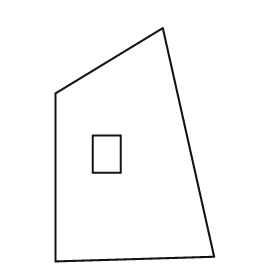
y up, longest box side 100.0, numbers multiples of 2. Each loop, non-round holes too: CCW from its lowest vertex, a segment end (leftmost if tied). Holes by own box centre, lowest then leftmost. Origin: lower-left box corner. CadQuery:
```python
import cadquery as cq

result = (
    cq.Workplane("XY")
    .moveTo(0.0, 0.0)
    .lineTo(68.0, 2.0)
    .lineTo(46.0, 100.0)
    .lineTo(0.0, 72.0)
    .close()
    .moveTo(16.0, 38.0)
    .lineTo(28.0, 38.0)
    .lineTo(28.0, 54.0)
    .lineTo(16.0, 54.0)
    .close()
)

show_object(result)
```